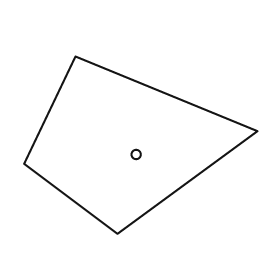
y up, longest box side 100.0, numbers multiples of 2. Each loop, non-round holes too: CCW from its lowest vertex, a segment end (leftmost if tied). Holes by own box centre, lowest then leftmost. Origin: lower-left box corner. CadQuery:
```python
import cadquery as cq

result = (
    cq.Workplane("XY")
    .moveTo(40.0, 0.0)
    .lineTo(100.0, 44.0)
    .lineTo(22.0, 76.0)
    .lineTo(0.0, 30.0)
    .close()
    .moveTo(48.0, 34.0)
    .circle(2.0)
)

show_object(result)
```